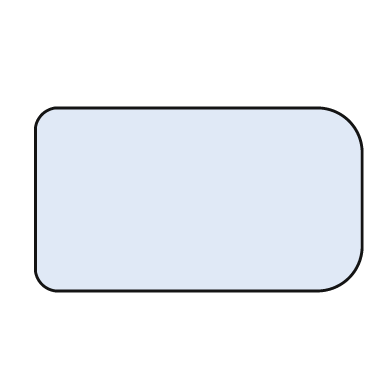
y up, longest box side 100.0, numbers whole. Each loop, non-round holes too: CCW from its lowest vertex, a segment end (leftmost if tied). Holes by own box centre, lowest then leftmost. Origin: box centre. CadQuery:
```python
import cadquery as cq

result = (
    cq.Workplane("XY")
    .moveTo(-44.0, -28.0)
    .lineTo(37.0, -28.0)
    .threePointArc((46.0, -24.0), (50.0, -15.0))
    .lineTo(50.0, 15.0)
    .threePointArc((46.0, 24.0), (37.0, 28.0))
    .lineTo(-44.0, 28.0)
    .threePointArc((-48.0, 26.0), (-50.0, 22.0))
    .lineTo(-50.0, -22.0)
    .threePointArc((-48.0, -26.0), (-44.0, -28.0))
    .close()
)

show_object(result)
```